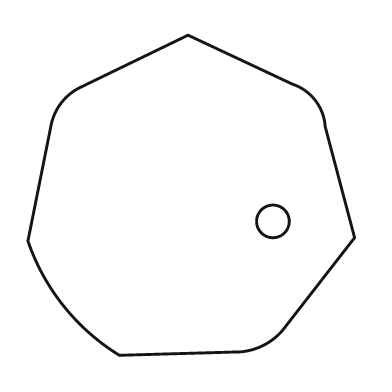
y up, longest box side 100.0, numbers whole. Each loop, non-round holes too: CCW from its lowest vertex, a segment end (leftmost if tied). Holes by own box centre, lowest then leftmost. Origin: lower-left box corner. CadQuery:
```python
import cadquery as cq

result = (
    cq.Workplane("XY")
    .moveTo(28.0, 0.0)
    .lineTo(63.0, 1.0)
    .threePointArc((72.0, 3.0), (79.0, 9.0))
    .lineTo(100.0, 36.0)
    .lineTo(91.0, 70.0)
    .threePointArc((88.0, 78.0), (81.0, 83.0))
    .lineTo(49.0, 98.0)
    .lineTo(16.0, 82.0)
    .threePointArc((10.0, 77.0), (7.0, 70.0))
    .lineTo(0.0, 35.0)
    .threePointArc((11.0, 15.0), (28.0, 0.0))
    .close()
    .moveTo(75.0, 41.0)
    .circle(5.0)
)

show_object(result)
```